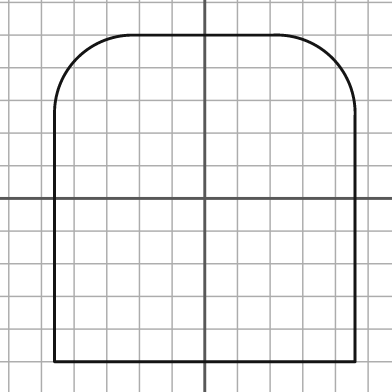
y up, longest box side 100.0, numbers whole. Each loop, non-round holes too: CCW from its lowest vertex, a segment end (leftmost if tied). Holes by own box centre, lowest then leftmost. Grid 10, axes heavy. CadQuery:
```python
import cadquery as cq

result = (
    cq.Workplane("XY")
    .moveTo(-46.0, -50.0)
    .lineTo(46.0, -50.0)
    .lineTo(46.0, 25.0)
    .threePointArc((39.0, 43.0), (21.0, 50.0))
    .lineTo(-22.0, 50.0)
    .threePointArc((-39.0, 43.0), (-46.0, 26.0))
    .close()
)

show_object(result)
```